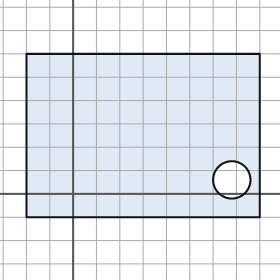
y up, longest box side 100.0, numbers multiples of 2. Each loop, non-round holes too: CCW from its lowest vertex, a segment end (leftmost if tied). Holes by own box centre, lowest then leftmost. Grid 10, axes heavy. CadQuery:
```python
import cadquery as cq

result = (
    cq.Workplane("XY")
    .moveTo(-20.0, -10.0)
    .lineTo(80.0, -10.0)
    .lineTo(80.0, 60.0)
    .lineTo(-20.0, 60.0)
    .close()
    .moveTo(68.0, 6.0)
    .circle(8.0)
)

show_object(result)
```